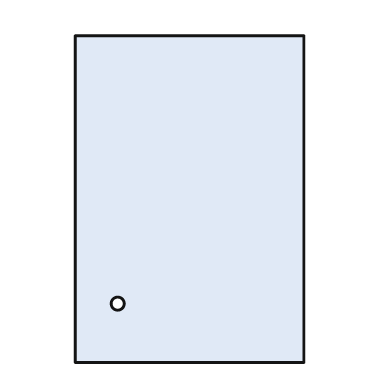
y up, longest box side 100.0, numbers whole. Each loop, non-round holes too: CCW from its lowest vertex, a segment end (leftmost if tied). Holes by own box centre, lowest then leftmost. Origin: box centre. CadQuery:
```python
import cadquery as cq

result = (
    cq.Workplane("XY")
    .moveTo(-35.0, -50.0)
    .lineTo(35.0, -50.0)
    .lineTo(35.0, 50.0)
    .lineTo(-35.0, 50.0)
    .close()
    .moveTo(-22.0, -32.0)
    .circle(2.0)
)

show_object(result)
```